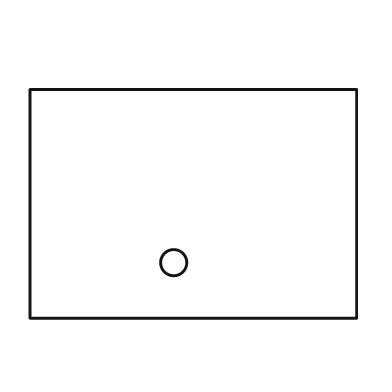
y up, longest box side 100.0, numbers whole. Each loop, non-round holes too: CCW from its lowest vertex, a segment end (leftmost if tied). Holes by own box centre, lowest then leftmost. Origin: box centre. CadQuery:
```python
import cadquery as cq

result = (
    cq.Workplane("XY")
    .moveTo(-50.0, -35.0)
    .lineTo(50.0, -35.0)
    .lineTo(50.0, 35.0)
    .lineTo(-50.0, 35.0)
    .close()
    .moveTo(-6.0, -18.0)
    .circle(4.0)
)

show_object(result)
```